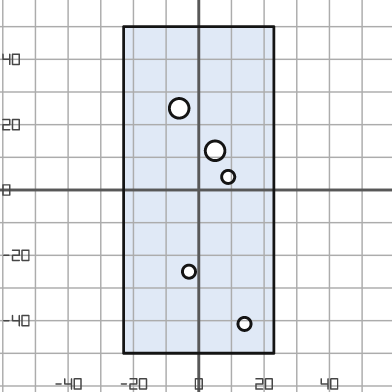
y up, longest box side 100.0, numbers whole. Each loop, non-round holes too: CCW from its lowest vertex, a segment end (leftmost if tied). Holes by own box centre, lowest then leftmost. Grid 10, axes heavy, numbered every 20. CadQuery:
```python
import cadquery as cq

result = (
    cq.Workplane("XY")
    .moveTo(-23.0, -50.0)
    .lineTo(23.0, -50.0)
    .lineTo(23.0, 50.0)
    .lineTo(-23.0, 50.0)
    .close()
    .moveTo(14.0, -41.0)
    .circle(2.0)
    .moveTo(-3.0, -25.0)
    .circle(2.0)
    .moveTo(9.0, 4.0)
    .circle(2.0)
    .moveTo(5.0, 12.0)
    .circle(3.0)
    .moveTo(-6.0, 25.0)
    .circle(3.0)
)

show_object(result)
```